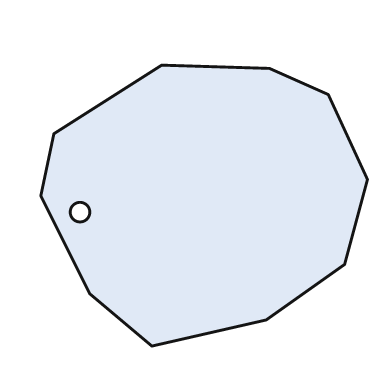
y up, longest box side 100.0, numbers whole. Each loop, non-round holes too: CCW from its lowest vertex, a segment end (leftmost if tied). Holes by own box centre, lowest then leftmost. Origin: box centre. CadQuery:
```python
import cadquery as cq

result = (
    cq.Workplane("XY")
    .moveTo(-16.0, -43.0)
    .lineTo(19.0, -35.0)
    .lineTo(43.0, -18.0)
    .lineTo(50.0, 8.0)
    .lineTo(38.0, 34.0)
    .lineTo(20.0, 42.0)
    .lineTo(-13.0, 43.0)
    .lineTo(-46.0, 22.0)
    .lineTo(-50.0, 3.0)
    .lineTo(-35.0, -27.0)
    .close()
    .moveTo(-38.0, -2.0)
    .circle(3.0)
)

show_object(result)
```